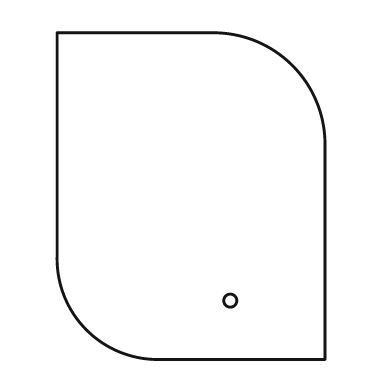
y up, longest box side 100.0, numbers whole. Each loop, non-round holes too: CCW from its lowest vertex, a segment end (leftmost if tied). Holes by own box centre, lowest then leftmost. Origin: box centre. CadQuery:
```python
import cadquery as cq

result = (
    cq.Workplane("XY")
    .moveTo(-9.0, -50.0)
    .lineTo(41.0, -50.0)
    .lineTo(41.0, 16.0)
    .threePointArc((31.0, 40.0), (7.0, 50.0))
    .lineTo(-41.0, 50.0)
    .lineTo(-41.0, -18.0)
    .threePointArc((-32.0, -41.0), (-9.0, -50.0))
    .close()
    .moveTo(12.0, -32.0)
    .circle(2.0)
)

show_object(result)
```